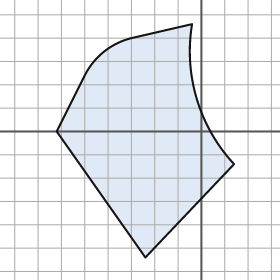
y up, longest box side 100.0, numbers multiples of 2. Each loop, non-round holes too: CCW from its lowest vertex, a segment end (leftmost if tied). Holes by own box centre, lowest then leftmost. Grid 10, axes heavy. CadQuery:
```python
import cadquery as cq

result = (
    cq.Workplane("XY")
    .moveTo(-24.0, -54.0)
    .lineTo(14.0, -14.0)
    .threePointArc((-2.0, 14.0), (-4.0, 46.0))
    .lineTo(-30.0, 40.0)
    .threePointArc((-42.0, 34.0), (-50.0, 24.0))
    .lineTo(-62.0, 0.0)
    .close()
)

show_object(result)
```